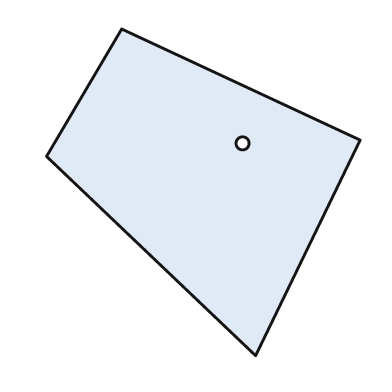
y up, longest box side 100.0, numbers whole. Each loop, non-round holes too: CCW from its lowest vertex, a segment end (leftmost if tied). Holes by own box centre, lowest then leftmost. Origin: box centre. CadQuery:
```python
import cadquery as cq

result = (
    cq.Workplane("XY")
    .moveTo(16.0, -50.0)
    .lineTo(48.0, 16.0)
    .lineTo(-25.0, 50.0)
    .lineTo(-48.0, 11.0)
    .close()
    .moveTo(12.0, 15.0)
    .circle(2.0)
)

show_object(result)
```